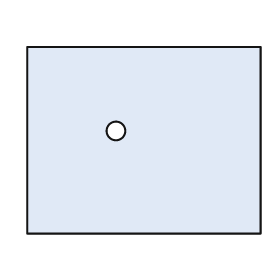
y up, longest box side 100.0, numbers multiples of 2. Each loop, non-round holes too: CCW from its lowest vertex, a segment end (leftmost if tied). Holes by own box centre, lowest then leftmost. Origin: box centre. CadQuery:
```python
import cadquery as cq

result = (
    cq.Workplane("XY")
    .moveTo(-50.0, -40.0)
    .lineTo(50.0, -40.0)
    .lineTo(50.0, 40.0)
    .lineTo(-50.0, 40.0)
    .close()
    .moveTo(-12.0, 4.0)
    .circle(4.0)
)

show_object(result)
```